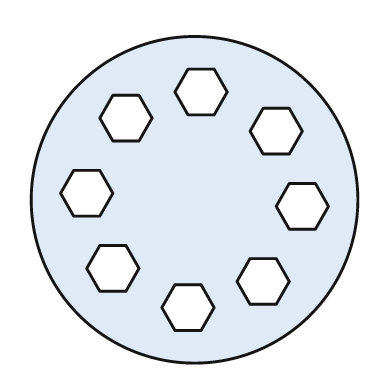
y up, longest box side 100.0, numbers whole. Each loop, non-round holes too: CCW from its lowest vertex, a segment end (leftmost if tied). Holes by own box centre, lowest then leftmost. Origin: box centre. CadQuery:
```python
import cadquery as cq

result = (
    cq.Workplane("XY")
    .moveTo(0.0, 0.0)
    .circle(50.0)
    .moveTo(-6.0, -40.0)
    .lineTo(2.0, -40.0)
    .lineTo(6.0, -33.0)
    .lineTo(2.0, -26.0)
    .lineTo(-6.0, -26.0)
    .lineTo(-10.0, -33.0)
    .close()
    .moveTo(17.0, -32.0)
    .lineTo(25.0, -32.0)
    .lineTo(29.0, -25.0)
    .lineTo(25.0, -18.0)
    .lineTo(17.0, -18.0)
    .lineTo(13.0, -25.0)
    .close()
    .moveTo(-29.0, -28.0)
    .lineTo(-21.0, -28.0)
    .lineTo(-17.0, -21.0)
    .lineTo(-21.0, -14.0)
    .lineTo(-29.0, -14.0)
    .lineTo(-33.0, -21.0)
    .close()
    .moveTo(29.0, -9.0)
    .lineTo(37.0, -9.0)
    .lineTo(41.0, -2.0)
    .lineTo(37.0, 5.0)
    .lineTo(29.0, 5.0)
    .lineTo(25.0, -2.0)
    .close()
    .moveTo(-37.0, -5.0)
    .lineTo(-29.0, -5.0)
    .lineTo(-25.0, 2.0)
    .lineTo(-29.0, 9.0)
    .lineTo(-37.0, 9.0)
    .lineTo(-41.0, 2.0)
    .close()
    .moveTo(21.0, 14.0)
    .lineTo(29.0, 14.0)
    .lineTo(33.0, 21.0)
    .lineTo(29.0, 28.0)
    .lineTo(21.0, 28.0)
    .lineTo(17.0, 21.0)
    .close()
    .moveTo(-25.0, 18.0)
    .lineTo(-17.0, 18.0)
    .lineTo(-13.0, 25.0)
    .lineTo(-17.0, 32.0)
    .lineTo(-25.0, 32.0)
    .lineTo(-29.0, 25.0)
    .close()
    .moveTo(-2.0, 26.0)
    .lineTo(6.0, 26.0)
    .lineTo(10.0, 33.0)
    .lineTo(6.0, 40.0)
    .lineTo(-2.0, 40.0)
    .lineTo(-6.0, 33.0)
    .close()
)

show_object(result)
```